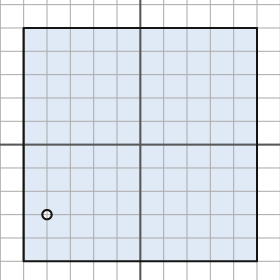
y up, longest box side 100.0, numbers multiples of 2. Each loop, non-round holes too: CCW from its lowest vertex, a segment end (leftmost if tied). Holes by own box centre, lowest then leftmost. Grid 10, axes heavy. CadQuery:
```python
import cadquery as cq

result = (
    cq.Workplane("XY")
    .moveTo(-50.0, -50.0)
    .lineTo(50.0, -50.0)
    .lineTo(50.0, 50.0)
    .lineTo(-50.0, 50.0)
    .close()
    .moveTo(-40.0, -30.0)
    .circle(2.0)
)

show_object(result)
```